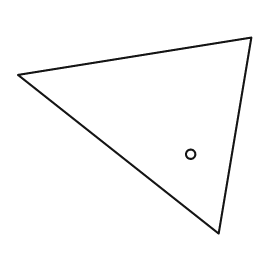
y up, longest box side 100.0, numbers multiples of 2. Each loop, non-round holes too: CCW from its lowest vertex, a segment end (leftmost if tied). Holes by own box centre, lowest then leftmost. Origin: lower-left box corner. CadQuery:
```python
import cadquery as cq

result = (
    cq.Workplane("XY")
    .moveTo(86.0, 0.0)
    .lineTo(100.0, 84.0)
    .lineTo(0.0, 68.0)
    .close()
    .moveTo(74.0, 34.0)
    .circle(2.0)
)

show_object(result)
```